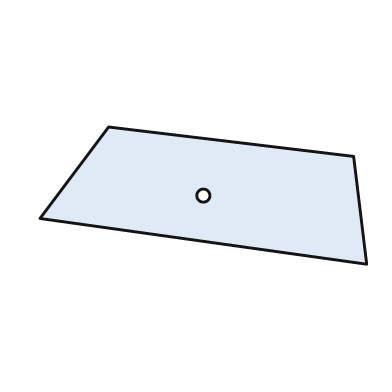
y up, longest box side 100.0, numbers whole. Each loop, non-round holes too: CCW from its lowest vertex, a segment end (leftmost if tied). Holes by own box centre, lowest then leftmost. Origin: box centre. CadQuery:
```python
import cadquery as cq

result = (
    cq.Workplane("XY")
    .moveTo(50.0, -21.0)
    .lineTo(46.0, 12.0)
    .lineTo(-29.0, 21.0)
    .lineTo(-50.0, -7.0)
    .close()
    .moveTo(0.0, 0.0)
    .circle(2.0)
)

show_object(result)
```